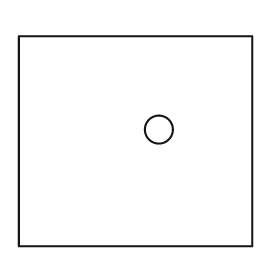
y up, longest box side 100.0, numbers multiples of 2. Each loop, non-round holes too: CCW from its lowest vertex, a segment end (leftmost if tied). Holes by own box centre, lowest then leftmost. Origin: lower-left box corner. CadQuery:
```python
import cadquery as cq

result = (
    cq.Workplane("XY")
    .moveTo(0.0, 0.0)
    .lineTo(100.0, 0.0)
    .lineTo(100.0, 90.0)
    .lineTo(0.0, 90.0)
    .close()
    .moveTo(60.0, 50.0)
    .circle(6.0)
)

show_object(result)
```